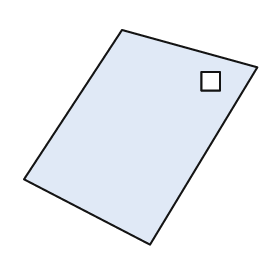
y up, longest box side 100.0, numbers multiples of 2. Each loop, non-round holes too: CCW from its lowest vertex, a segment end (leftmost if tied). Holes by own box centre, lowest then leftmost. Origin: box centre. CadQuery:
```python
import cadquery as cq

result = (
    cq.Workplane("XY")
    .moveTo(4.0, -46.0)
    .lineTo(50.0, 30.0)
    .lineTo(-8.0, 46.0)
    .lineTo(-50.0, -18.0)
    .close()
    .moveTo(26.0, 20.0)
    .lineTo(34.0, 20.0)
    .lineTo(34.0, 28.0)
    .lineTo(26.0, 28.0)
    .close()
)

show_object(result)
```